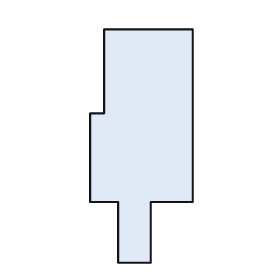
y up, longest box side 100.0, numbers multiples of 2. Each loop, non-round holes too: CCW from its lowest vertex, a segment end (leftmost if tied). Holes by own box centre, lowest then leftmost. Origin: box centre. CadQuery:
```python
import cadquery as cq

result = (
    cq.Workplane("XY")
    .moveTo(-10.0, -50.0)
    .lineTo(4.0, -50.0)
    .lineTo(4.0, -24.0)
    .lineTo(22.0, -24.0)
    .lineTo(22.0, 50.0)
    .lineTo(-16.0, 50.0)
    .lineTo(-16.0, 14.0)
    .lineTo(-22.0, 14.0)
    .lineTo(-22.0, -24.0)
    .lineTo(-10.0, -24.0)
    .close()
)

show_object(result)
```